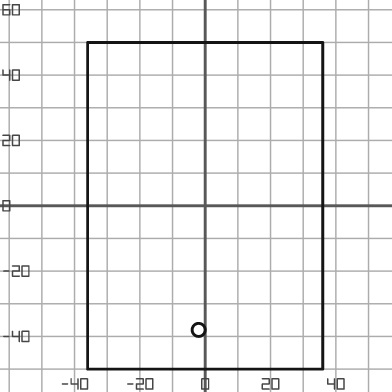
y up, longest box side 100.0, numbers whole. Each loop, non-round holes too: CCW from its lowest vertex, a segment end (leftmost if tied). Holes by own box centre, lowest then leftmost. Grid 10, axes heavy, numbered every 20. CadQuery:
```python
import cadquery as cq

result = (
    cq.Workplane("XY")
    .moveTo(-36.0, -50.0)
    .lineTo(36.0, -50.0)
    .lineTo(36.0, 50.0)
    .lineTo(-36.0, 50.0)
    .close()
    .moveTo(-2.0, -38.0)
    .circle(2.0)
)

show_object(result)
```